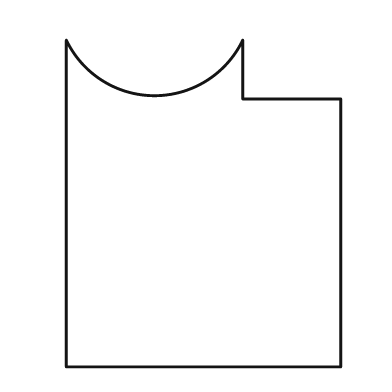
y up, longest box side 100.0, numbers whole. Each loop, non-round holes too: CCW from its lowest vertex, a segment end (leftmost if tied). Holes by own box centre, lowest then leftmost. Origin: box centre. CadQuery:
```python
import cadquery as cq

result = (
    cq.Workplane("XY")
    .moveTo(-42.0, -50.0)
    .lineTo(42.0, -50.0)
    .lineTo(42.0, 32.0)
    .lineTo(12.0, 32.0)
    .lineTo(12.0, 50.0)
    .threePointArc((-15.0, 33.0), (-42.0, 50.0))
    .close()
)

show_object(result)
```